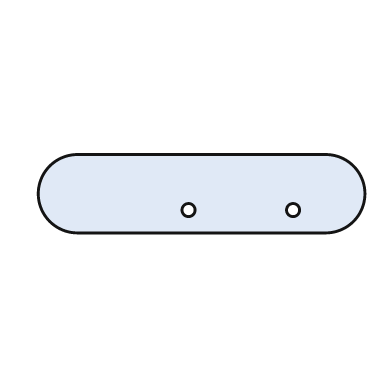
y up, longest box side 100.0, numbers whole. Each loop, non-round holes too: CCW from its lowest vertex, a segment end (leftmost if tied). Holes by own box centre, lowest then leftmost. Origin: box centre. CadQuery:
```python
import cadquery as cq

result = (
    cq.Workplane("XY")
    .moveTo(-38.0, -12.0)
    .lineTo(38.0, -12.0)
    .threePointArc((50.0, 0.0), (38.0, 12.0))
    .lineTo(-38.0, 12.0)
    .threePointArc((-50.0, 0.0), (-38.0, -12.0))
    .close()
    .moveTo(-4.0, -5.0)
    .circle(2.0)
    .moveTo(28.0, -5.0)
    .circle(2.0)
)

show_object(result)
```